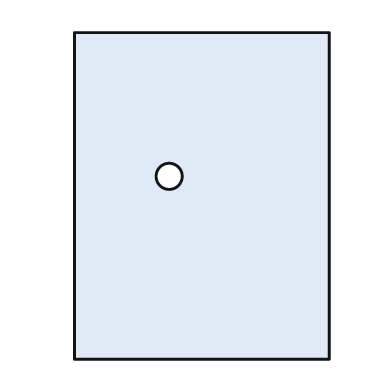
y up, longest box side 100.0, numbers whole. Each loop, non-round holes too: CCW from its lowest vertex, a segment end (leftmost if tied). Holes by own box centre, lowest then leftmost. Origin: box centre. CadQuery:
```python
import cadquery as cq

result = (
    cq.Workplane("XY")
    .moveTo(-39.0, -50.0)
    .lineTo(39.0, -50.0)
    .lineTo(39.0, 50.0)
    .lineTo(-39.0, 50.0)
    .close()
    .moveTo(-10.0, 6.0)
    .circle(4.0)
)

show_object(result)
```